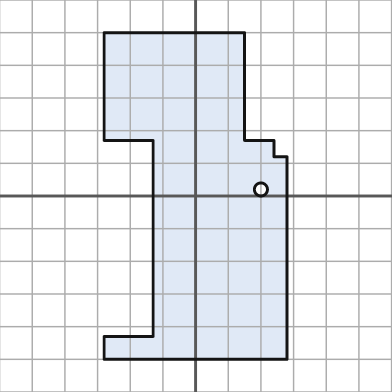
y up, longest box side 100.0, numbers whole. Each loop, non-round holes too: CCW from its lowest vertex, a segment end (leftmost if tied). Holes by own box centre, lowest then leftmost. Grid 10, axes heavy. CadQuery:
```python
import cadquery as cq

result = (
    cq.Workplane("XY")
    .moveTo(-28.0, -50.0)
    .lineTo(28.0, -50.0)
    .lineTo(28.0, 12.0)
    .lineTo(24.0, 12.0)
    .lineTo(24.0, 17.0)
    .lineTo(15.0, 17.0)
    .lineTo(15.0, 50.0)
    .lineTo(-28.0, 50.0)
    .lineTo(-28.0, 17.0)
    .lineTo(-13.0, 17.0)
    .lineTo(-13.0, -43.0)
    .lineTo(-28.0, -43.0)
    .close()
    .moveTo(20.0, 2.0)
    .circle(2.0)
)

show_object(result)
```